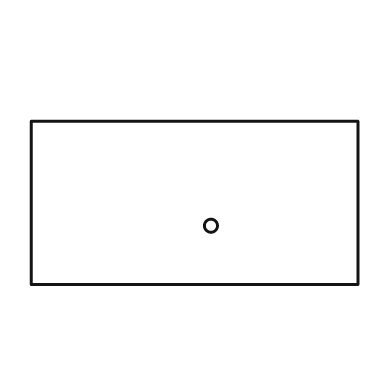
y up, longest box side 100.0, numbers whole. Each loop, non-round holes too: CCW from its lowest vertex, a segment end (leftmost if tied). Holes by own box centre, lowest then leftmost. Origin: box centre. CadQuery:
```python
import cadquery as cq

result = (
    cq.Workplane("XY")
    .moveTo(-50.0, -25.0)
    .lineTo(50.0, -25.0)
    .lineTo(50.0, 25.0)
    .lineTo(-50.0, 25.0)
    .close()
    .moveTo(5.0, -7.0)
    .circle(2.0)
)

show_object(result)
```